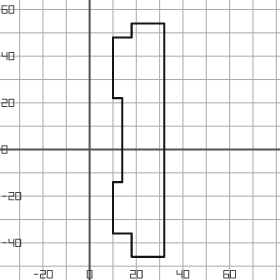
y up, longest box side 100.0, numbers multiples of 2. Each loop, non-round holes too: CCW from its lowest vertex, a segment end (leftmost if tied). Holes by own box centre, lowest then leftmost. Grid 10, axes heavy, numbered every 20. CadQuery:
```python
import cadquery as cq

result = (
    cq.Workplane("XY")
    .moveTo(18.0, -46.0)
    .lineTo(32.0, -46.0)
    .lineTo(32.0, 54.0)
    .lineTo(18.0, 54.0)
    .lineTo(18.0, 48.0)
    .lineTo(10.0, 48.0)
    .lineTo(10.0, 22.0)
    .lineTo(14.0, 22.0)
    .lineTo(14.0, -14.0)
    .lineTo(10.0, -14.0)
    .lineTo(10.0, -36.0)
    .lineTo(18.0, -36.0)
    .close()
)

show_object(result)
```